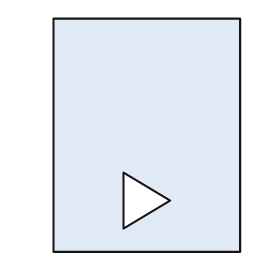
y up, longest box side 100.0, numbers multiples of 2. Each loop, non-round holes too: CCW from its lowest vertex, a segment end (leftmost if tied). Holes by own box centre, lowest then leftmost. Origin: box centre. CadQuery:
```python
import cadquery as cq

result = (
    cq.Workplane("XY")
    .moveTo(-40.0, -50.0)
    .lineTo(40.0, -50.0)
    .lineTo(40.0, 50.0)
    .lineTo(-40.0, 50.0)
    .close()
    .moveTo(-10.0, -40.0)
    .lineTo(10.0, -28.0)
    .lineTo(-10.0, -16.0)
    .close()
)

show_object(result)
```